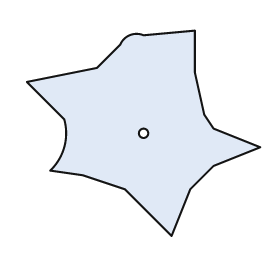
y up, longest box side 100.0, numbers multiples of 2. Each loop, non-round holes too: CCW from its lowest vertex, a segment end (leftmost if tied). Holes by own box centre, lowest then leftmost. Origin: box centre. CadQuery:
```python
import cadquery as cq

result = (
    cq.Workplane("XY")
    .moveTo(12.0, -44.0)
    .lineTo(20.0, -24.0)
    .lineTo(30.0, -14.0)
    .lineTo(50.0, -6.0)
    .lineTo(30.0, 2.0)
    .lineTo(26.0, 8.0)
    .lineTo(22.0, 26.0)
    .lineTo(22.0, 44.0)
    .lineTo(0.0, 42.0)
    .threePointArc((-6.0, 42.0), (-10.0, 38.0))
    .lineTo(-20.0, 28.0)
    .lineTo(-50.0, 22.0)
    .lineTo(-34.0, 6.0)
    .threePointArc((-34.0, -6.0), (-40.0, -16.0))
    .lineTo(-26.0, -18.0)
    .lineTo(-8.0, -24.0)
    .close()
    .moveTo(0.0, 0.0)
    .circle(2.0)
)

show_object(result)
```